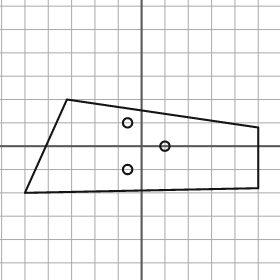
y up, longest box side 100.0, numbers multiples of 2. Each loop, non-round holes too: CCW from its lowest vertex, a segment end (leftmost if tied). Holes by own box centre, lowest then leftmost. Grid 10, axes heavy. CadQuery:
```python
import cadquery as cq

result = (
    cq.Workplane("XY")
    .moveTo(-50.0, -20.0)
    .lineTo(50.0, -18.0)
    .lineTo(50.0, 8.0)
    .lineTo(-32.0, 20.0)
    .close()
    .moveTo(-6.0, -10.0)
    .circle(2.0)
    .moveTo(10.0, 0.0)
    .circle(2.0)
    .moveTo(-6.0, 10.0)
    .circle(2.0)
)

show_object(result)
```